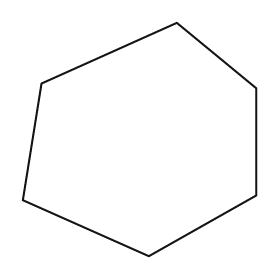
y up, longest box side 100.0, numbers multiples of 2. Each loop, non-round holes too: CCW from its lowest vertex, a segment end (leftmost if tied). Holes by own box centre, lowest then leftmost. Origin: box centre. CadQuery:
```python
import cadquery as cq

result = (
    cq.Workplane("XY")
    .moveTo(4.0, -50.0)
    .lineTo(50.0, -24.0)
    .lineTo(50.0, 22.0)
    .lineTo(16.0, 50.0)
    .lineTo(-42.0, 24.0)
    .lineTo(-50.0, -26.0)
    .close()
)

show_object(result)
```